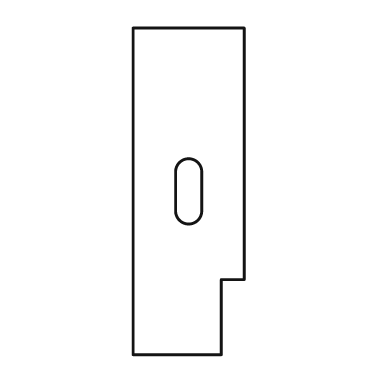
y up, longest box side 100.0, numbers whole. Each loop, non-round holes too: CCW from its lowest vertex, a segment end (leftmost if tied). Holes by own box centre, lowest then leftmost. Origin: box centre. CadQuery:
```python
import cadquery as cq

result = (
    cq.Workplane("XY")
    .moveTo(-17.0, -50.0)
    .lineTo(10.0, -50.0)
    .lineTo(10.0, -27.0)
    .lineTo(17.0, -27.0)
    .lineTo(17.0, 50.0)
    .lineTo(-17.0, 50.0)
    .close()
    .moveTo(-4.0, -6.0)
    .threePointArc((0.0, -10.0), (4.0, -6.0))
    .lineTo(4.0, 6.0)
    .threePointArc((0.0, 10.0), (-4.0, 6.0))
    .close()
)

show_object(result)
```